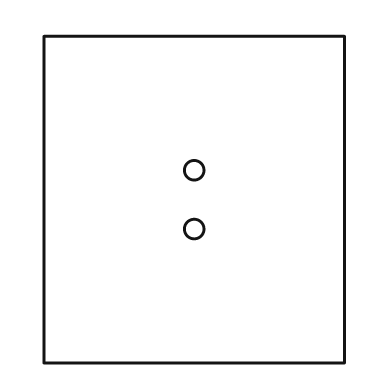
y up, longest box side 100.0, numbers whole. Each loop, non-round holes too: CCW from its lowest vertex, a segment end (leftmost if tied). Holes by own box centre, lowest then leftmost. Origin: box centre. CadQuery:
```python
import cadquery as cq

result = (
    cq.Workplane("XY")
    .moveTo(-46.0, -50.0)
    .lineTo(46.0, -50.0)
    .lineTo(46.0, 50.0)
    .lineTo(-46.0, 50.0)
    .close()
    .moveTo(0.0, -9.0)
    .circle(3.0)
    .moveTo(0.0, 9.0)
    .circle(3.0)
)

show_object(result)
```